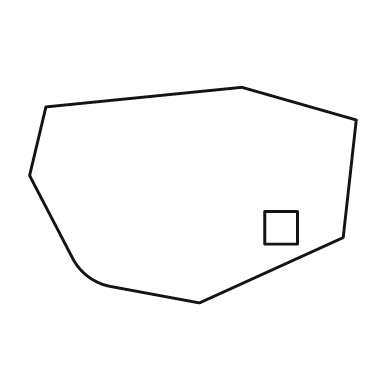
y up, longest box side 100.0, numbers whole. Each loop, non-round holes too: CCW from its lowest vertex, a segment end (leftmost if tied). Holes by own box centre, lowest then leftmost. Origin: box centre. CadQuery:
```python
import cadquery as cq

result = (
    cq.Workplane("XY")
    .moveTo(2.0, -33.0)
    .lineTo(46.0, -13.0)
    .lineTo(50.0, 23.0)
    .lineTo(15.0, 33.0)
    .lineTo(-45.0, 27.0)
    .lineTo(-50.0, 6.0)
    .lineTo(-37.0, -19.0)
    .threePointArc((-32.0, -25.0), (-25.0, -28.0))
    .close()
    .moveTo(22.0, -15.0)
    .lineTo(32.0, -15.0)
    .lineTo(32.0, -5.0)
    .lineTo(22.0, -5.0)
    .close()
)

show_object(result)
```